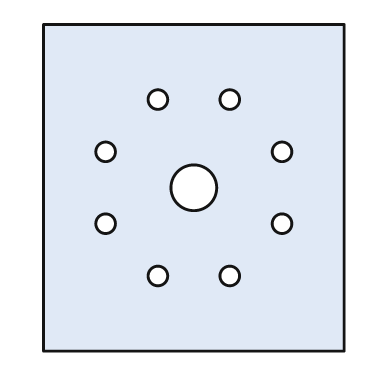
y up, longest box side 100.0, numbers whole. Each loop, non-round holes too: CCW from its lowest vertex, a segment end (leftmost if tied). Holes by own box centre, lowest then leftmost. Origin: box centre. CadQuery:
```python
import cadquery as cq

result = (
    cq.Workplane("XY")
    .moveTo(-46.0, -50.0)
    .lineTo(46.0, -50.0)
    .lineTo(46.0, 50.0)
    .lineTo(-46.0, 50.0)
    .close()
    .moveTo(-11.0, -27.0)
    .circle(3.0)
    .moveTo(11.0, -27.0)
    .circle(3.0)
    .moveTo(-27.0, -11.0)
    .circle(3.0)
    .moveTo(27.0, -11.0)
    .circle(3.0)
    .moveTo(0.0, 0.0)
    .circle(7.0)
    .moveTo(-27.0, 11.0)
    .circle(3.0)
    .moveTo(27.0, 11.0)
    .circle(3.0)
    .moveTo(-11.0, 27.0)
    .circle(3.0)
    .moveTo(11.0, 27.0)
    .circle(3.0)
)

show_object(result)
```